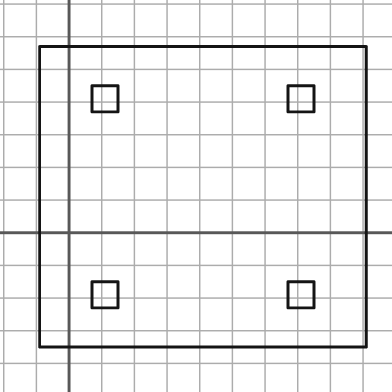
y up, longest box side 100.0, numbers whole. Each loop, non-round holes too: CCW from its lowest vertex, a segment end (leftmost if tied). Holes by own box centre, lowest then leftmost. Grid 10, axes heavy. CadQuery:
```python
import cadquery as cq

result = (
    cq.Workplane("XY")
    .moveTo(-9.0, -35.0)
    .lineTo(91.0, -35.0)
    .lineTo(91.0, 57.0)
    .lineTo(-9.0, 57.0)
    .close()
    .moveTo(7.0, -23.0)
    .lineTo(15.0, -23.0)
    .lineTo(15.0, -15.0)
    .lineTo(7.0, -15.0)
    .close()
    .moveTo(67.0, -23.0)
    .lineTo(75.0, -23.0)
    .lineTo(75.0, -15.0)
    .lineTo(67.0, -15.0)
    .close()
    .moveTo(7.0, 37.0)
    .lineTo(15.0, 37.0)
    .lineTo(15.0, 45.0)
    .lineTo(7.0, 45.0)
    .close()
    .moveTo(67.0, 37.0)
    .lineTo(75.0, 37.0)
    .lineTo(75.0, 45.0)
    .lineTo(67.0, 45.0)
    .close()
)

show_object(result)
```